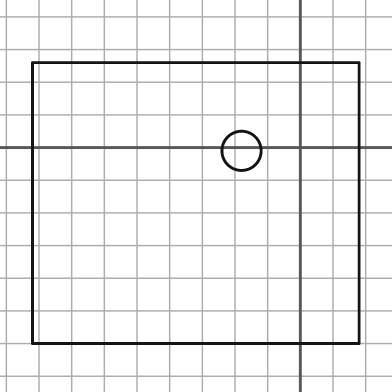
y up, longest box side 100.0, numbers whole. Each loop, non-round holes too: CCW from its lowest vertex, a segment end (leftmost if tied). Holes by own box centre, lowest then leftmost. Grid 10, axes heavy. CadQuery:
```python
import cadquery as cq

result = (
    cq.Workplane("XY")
    .moveTo(-82.0, -60.0)
    .lineTo(18.0, -60.0)
    .lineTo(18.0, 26.0)
    .lineTo(-82.0, 26.0)
    .close()
    .moveTo(-18.0, -1.0)
    .circle(6.0)
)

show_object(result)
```